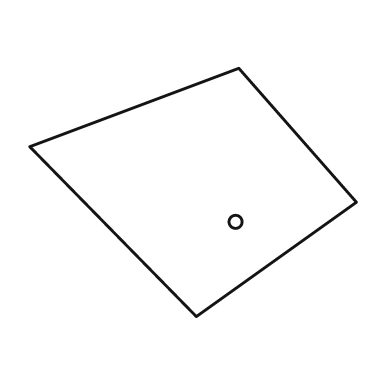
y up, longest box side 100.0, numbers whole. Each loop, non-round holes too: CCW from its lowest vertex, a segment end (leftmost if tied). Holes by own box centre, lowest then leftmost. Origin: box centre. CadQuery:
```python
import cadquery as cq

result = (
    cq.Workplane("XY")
    .moveTo(1.0, -38.0)
    .lineTo(50.0, -3.0)
    .lineTo(14.0, 38.0)
    .lineTo(-50.0, 14.0)
    .close()
    .moveTo(13.0, -9.0)
    .circle(2.0)
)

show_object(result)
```